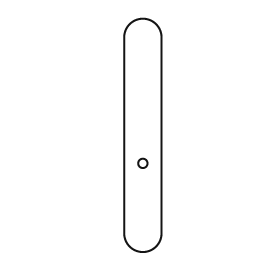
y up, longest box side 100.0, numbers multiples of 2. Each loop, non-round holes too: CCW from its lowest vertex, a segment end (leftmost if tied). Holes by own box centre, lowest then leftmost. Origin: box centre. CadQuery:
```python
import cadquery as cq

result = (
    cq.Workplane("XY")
    .moveTo(-8.0, -42.0)
    .threePointArc((0.0, -50.0), (8.0, -42.0))
    .lineTo(8.0, 42.0)
    .threePointArc((0.0, 50.0), (-8.0, 42.0))
    .close()
    .moveTo(0.0, -12.0)
    .circle(2.0)
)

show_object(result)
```